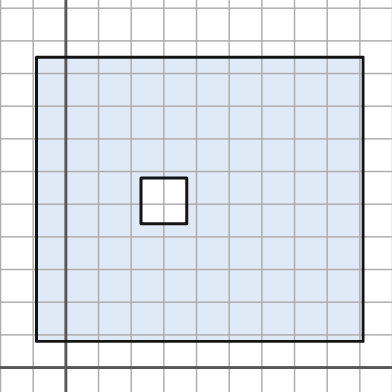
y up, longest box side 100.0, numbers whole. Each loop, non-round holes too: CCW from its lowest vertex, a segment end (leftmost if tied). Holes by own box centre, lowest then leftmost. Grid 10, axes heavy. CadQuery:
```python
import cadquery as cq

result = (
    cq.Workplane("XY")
    .moveTo(-9.0, 8.0)
    .lineTo(91.0, 8.0)
    .lineTo(91.0, 95.0)
    .lineTo(-9.0, 95.0)
    .close()
    .moveTo(23.0, 44.0)
    .lineTo(37.0, 44.0)
    .lineTo(37.0, 58.0)
    .lineTo(23.0, 58.0)
    .close()
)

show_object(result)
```